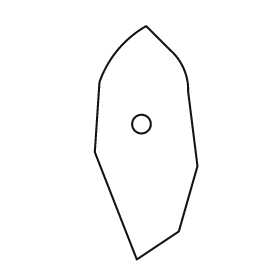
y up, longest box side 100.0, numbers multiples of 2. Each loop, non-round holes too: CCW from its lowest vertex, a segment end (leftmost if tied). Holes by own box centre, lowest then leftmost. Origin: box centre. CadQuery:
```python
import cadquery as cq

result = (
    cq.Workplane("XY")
    .moveTo(-4.0, -50.0)
    .lineTo(14.0, -38.0)
    .lineTo(22.0, -10.0)
    .lineTo(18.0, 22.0)
    .threePointArc((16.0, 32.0), (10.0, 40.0))
    .lineTo(0.0, 50.0)
    .threePointArc((-12.0, 40.0), (-20.0, 26.0))
    .lineTo(-22.0, -4.0)
    .close()
    .moveTo(-2.0, 8.0)
    .circle(4.0)
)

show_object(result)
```